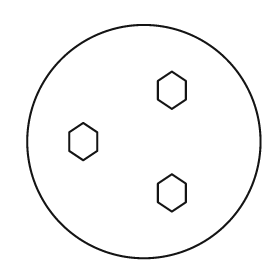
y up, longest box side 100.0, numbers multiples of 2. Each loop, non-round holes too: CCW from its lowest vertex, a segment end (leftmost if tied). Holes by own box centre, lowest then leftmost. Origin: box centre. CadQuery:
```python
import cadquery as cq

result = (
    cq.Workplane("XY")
    .moveTo(0.0, 0.0)
    .circle(50.0)
    .moveTo(12.0, -30.0)
    .lineTo(18.0, -26.0)
    .lineTo(18.0, -18.0)
    .lineTo(12.0, -14.0)
    .lineTo(6.0, -18.0)
    .lineTo(6.0, -26.0)
    .close()
    .moveTo(-26.0, -8.0)
    .lineTo(-20.0, -4.0)
    .lineTo(-20.0, 4.0)
    .lineTo(-26.0, 8.0)
    .lineTo(-32.0, 4.0)
    .lineTo(-32.0, -4.0)
    .close()
    .moveTo(12.0, 14.0)
    .lineTo(18.0, 18.0)
    .lineTo(18.0, 26.0)
    .lineTo(12.0, 30.0)
    .lineTo(6.0, 26.0)
    .lineTo(6.0, 18.0)
    .close()
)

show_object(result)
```